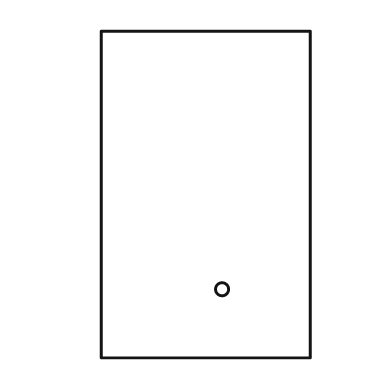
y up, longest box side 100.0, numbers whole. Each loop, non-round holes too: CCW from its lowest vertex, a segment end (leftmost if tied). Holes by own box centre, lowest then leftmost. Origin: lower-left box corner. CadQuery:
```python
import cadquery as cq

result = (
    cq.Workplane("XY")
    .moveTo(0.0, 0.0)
    .lineTo(64.0, 0.0)
    .lineTo(64.0, 100.0)
    .lineTo(0.0, 100.0)
    .close()
    .moveTo(37.0, 21.0)
    .circle(2.0)
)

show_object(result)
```